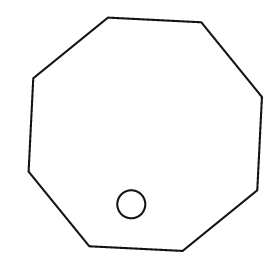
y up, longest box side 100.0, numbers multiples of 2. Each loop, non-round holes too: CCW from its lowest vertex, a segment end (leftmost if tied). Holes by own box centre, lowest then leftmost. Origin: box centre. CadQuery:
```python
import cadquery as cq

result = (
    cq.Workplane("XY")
    .moveTo(16.0, -50.0)
    .lineTo(48.0, -24.0)
    .lineTo(50.0, 16.0)
    .lineTo(24.0, 48.0)
    .lineTo(-16.0, 50.0)
    .lineTo(-48.0, 24.0)
    .lineTo(-50.0, -16.0)
    .lineTo(-24.0, -48.0)
    .close()
    .moveTo(-6.0, -30.0)
    .circle(6.0)
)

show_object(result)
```